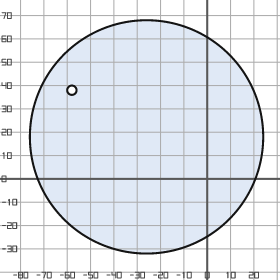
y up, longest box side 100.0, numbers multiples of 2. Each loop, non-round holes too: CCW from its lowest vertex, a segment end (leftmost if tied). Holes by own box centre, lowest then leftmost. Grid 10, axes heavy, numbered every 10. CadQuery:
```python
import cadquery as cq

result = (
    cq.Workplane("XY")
    .moveTo(-26.0, 18.0)
    .circle(50.0)
    .moveTo(-58.0, 38.0)
    .circle(2.0)
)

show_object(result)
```